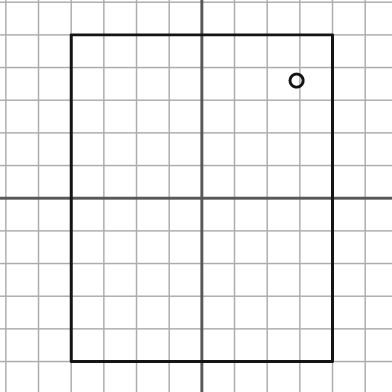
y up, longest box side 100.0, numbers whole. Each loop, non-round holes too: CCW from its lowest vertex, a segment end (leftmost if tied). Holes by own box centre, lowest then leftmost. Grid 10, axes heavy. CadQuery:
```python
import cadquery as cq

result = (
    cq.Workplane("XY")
    .moveTo(-40.0, -50.0)
    .lineTo(40.0, -50.0)
    .lineTo(40.0, 50.0)
    .lineTo(-40.0, 50.0)
    .close()
    .moveTo(29.0, 36.0)
    .circle(2.0)
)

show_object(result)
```